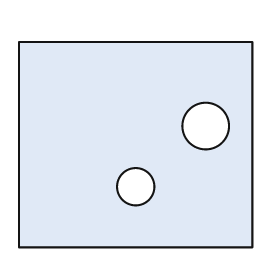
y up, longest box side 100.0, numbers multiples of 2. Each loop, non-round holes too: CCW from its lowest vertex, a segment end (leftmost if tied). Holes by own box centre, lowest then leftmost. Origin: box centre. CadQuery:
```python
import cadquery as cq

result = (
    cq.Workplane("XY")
    .moveTo(-50.0, -44.0)
    .lineTo(50.0, -44.0)
    .lineTo(50.0, 44.0)
    .lineTo(-50.0, 44.0)
    .close()
    .moveTo(0.0, -18.0)
    .circle(8.0)
    .moveTo(30.0, 8.0)
    .circle(10.0)
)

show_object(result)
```